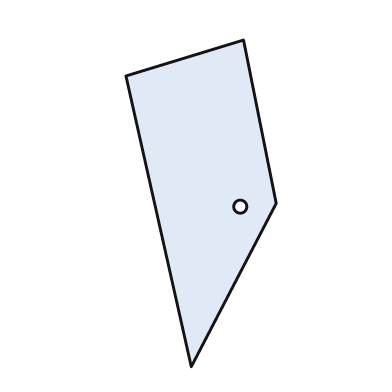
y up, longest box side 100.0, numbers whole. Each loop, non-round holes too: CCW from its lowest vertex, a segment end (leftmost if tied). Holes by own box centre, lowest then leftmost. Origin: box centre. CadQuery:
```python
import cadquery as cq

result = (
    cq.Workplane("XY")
    .moveTo(-3.0, -50.0)
    .lineTo(23.0, 0.0)
    .lineTo(13.0, 50.0)
    .lineTo(-23.0, 39.0)
    .close()
    .moveTo(12.0, -1.0)
    .circle(2.0)
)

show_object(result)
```